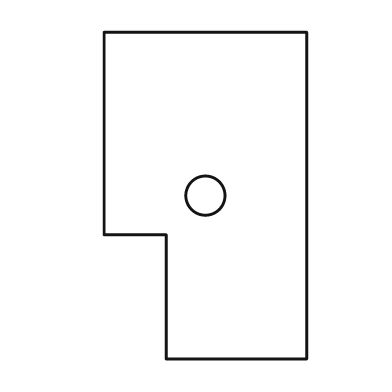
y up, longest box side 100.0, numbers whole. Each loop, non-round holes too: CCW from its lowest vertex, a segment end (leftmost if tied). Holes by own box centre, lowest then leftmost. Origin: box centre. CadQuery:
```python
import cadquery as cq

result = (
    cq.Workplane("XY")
    .moveTo(-12.0, -50.0)
    .lineTo(31.0, -50.0)
    .lineTo(31.0, 50.0)
    .lineTo(-31.0, 50.0)
    .lineTo(-31.0, -12.0)
    .lineTo(-12.0, -12.0)
    .close()
    .moveTo(0.0, 0.0)
    .circle(6.0)
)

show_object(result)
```